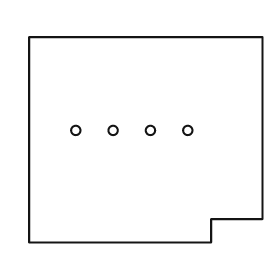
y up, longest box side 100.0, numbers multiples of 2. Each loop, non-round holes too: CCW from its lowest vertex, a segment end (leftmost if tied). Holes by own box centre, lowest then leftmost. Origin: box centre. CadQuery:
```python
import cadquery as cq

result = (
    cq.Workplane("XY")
    .moveTo(-50.0, -44.0)
    .lineTo(28.0, -44.0)
    .lineTo(28.0, -34.0)
    .lineTo(50.0, -34.0)
    .lineTo(50.0, 44.0)
    .lineTo(-50.0, 44.0)
    .close()
    .moveTo(-30.0, 4.0)
    .circle(2.0)
    .moveTo(-14.0, 4.0)
    .circle(2.0)
    .moveTo(2.0, 4.0)
    .circle(2.0)
    .moveTo(18.0, 4.0)
    .circle(2.0)
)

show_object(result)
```